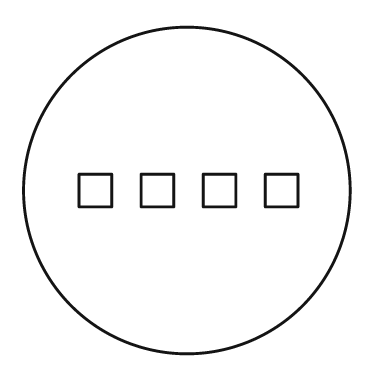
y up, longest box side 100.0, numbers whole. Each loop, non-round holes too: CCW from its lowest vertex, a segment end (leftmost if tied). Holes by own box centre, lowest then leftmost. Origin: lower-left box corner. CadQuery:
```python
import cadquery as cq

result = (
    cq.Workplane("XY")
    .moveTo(50.0, 50.0)
    .circle(50.0)
    .moveTo(17.0, 45.0)
    .lineTo(27.0, 45.0)
    .lineTo(27.0, 55.0)
    .lineTo(17.0, 55.0)
    .close()
    .moveTo(36.0, 45.0)
    .lineTo(46.0, 45.0)
    .lineTo(46.0, 55.0)
    .lineTo(36.0, 55.0)
    .close()
    .moveTo(55.0, 45.0)
    .lineTo(65.0, 45.0)
    .lineTo(65.0, 55.0)
    .lineTo(55.0, 55.0)
    .close()
    .moveTo(74.0, 45.0)
    .lineTo(84.0, 45.0)
    .lineTo(84.0, 55.0)
    .lineTo(74.0, 55.0)
    .close()
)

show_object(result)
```